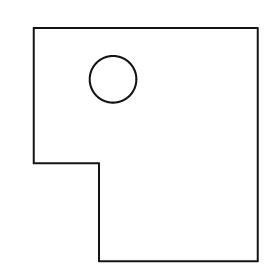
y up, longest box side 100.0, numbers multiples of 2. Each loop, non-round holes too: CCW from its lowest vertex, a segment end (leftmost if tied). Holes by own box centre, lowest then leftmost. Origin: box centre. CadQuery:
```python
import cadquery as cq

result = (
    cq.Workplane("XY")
    .moveTo(-20.0, -50.0)
    .lineTo(48.0, -50.0)
    .lineTo(48.0, 50.0)
    .lineTo(-48.0, 50.0)
    .lineTo(-48.0, -8.0)
    .lineTo(-20.0, -8.0)
    .close()
    .moveTo(-14.0, 28.0)
    .circle(10.0)
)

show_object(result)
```